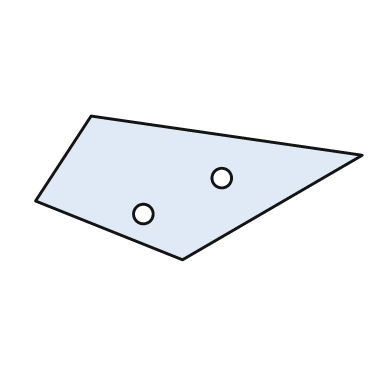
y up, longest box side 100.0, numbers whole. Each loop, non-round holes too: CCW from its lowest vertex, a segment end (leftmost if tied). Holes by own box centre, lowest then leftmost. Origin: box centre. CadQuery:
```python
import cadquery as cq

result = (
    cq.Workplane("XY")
    .moveTo(-5.0, -22.0)
    .lineTo(50.0, 10.0)
    .lineTo(-33.0, 22.0)
    .lineTo(-50.0, -4.0)
    .close()
    .moveTo(-17.0, -8.0)
    .circle(3.0)
    .moveTo(7.0, 3.0)
    .circle(3.0)
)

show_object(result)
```